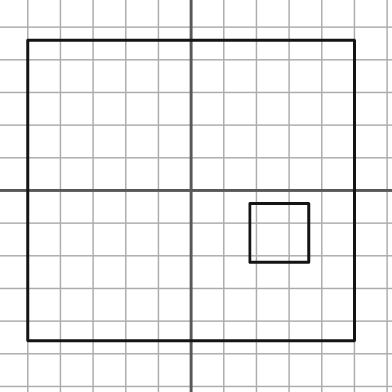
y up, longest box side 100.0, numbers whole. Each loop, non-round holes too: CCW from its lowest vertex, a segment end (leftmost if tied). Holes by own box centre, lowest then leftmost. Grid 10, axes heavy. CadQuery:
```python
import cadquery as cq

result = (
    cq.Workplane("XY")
    .moveTo(-50.0, -46.0)
    .lineTo(50.0, -46.0)
    .lineTo(50.0, 46.0)
    .lineTo(-50.0, 46.0)
    .close()
    .moveTo(18.0, -22.0)
    .lineTo(36.0, -22.0)
    .lineTo(36.0, -4.0)
    .lineTo(18.0, -4.0)
    .close()
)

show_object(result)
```